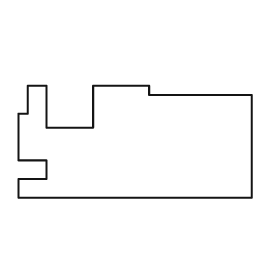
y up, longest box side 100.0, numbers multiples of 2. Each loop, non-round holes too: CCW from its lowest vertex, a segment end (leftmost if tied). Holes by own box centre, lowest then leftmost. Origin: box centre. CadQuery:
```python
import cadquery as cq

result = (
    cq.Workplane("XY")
    .moveTo(-50.0, -24.0)
    .lineTo(50.0, -24.0)
    .lineTo(50.0, 20.0)
    .lineTo(6.0, 20.0)
    .lineTo(6.0, 24.0)
    .lineTo(-18.0, 24.0)
    .lineTo(-18.0, 6.0)
    .lineTo(-38.0, 6.0)
    .lineTo(-38.0, 24.0)
    .lineTo(-46.0, 24.0)
    .lineTo(-46.0, 12.0)
    .lineTo(-50.0, 12.0)
    .lineTo(-50.0, -8.0)
    .lineTo(-38.0, -8.0)
    .lineTo(-38.0, -16.0)
    .lineTo(-50.0, -16.0)
    .close()
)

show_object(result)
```